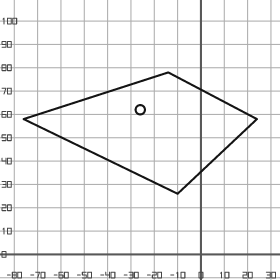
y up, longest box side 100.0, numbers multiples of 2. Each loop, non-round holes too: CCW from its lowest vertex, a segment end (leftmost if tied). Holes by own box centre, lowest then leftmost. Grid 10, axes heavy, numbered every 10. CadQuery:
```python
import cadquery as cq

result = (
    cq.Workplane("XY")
    .moveTo(-10.0, 26.0)
    .lineTo(24.0, 58.0)
    .lineTo(-14.0, 78.0)
    .lineTo(-76.0, 58.0)
    .close()
    .moveTo(-26.0, 62.0)
    .circle(2.0)
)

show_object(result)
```